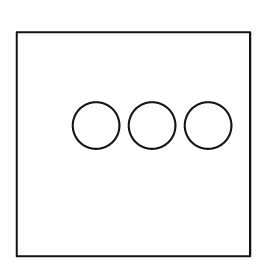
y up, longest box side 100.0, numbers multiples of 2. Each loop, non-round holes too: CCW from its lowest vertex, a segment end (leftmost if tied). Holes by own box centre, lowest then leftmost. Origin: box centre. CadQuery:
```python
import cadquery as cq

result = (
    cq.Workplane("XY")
    .moveTo(-50.0, -48.0)
    .lineTo(50.0, -48.0)
    .lineTo(50.0, 48.0)
    .lineTo(-50.0, 48.0)
    .close()
    .moveTo(-16.0, 8.0)
    .circle(10.0)
    .moveTo(8.0, 8.0)
    .circle(10.0)
    .moveTo(32.0, 8.0)
    .circle(10.0)
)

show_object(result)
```